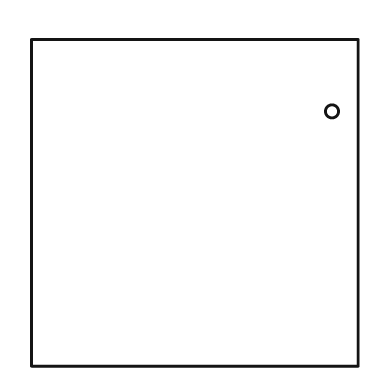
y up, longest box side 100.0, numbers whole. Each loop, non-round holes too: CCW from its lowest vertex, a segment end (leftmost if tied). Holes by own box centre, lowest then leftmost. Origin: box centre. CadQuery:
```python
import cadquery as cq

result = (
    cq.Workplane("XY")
    .moveTo(-50.0, -50.0)
    .lineTo(50.0, -50.0)
    .lineTo(50.0, 50.0)
    .lineTo(-50.0, 50.0)
    .close()
    .moveTo(42.0, 28.0)
    .circle(2.0)
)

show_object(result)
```